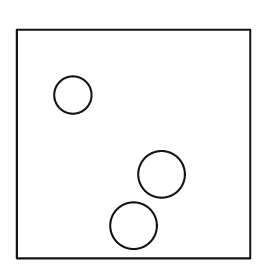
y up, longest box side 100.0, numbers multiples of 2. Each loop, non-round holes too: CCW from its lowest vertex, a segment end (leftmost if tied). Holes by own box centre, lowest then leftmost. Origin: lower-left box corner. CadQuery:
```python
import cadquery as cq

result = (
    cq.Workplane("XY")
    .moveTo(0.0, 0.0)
    .lineTo(100.0, 0.0)
    .lineTo(100.0, 98.0)
    .lineTo(0.0, 98.0)
    .close()
    .moveTo(50.0, 14.0)
    .circle(10.0)
    .moveTo(62.0, 36.0)
    .circle(10.0)
    .moveTo(24.0, 70.0)
    .circle(8.0)
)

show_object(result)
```